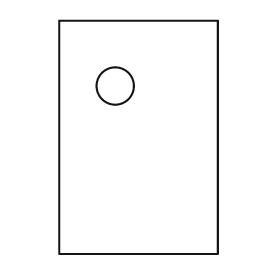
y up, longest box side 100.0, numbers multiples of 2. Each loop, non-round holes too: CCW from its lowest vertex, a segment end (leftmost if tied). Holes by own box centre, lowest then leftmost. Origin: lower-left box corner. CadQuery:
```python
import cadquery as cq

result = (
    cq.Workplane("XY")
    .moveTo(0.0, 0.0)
    .lineTo(68.0, 0.0)
    .lineTo(68.0, 100.0)
    .lineTo(0.0, 100.0)
    .close()
    .moveTo(24.0, 72.0)
    .circle(8.0)
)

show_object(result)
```